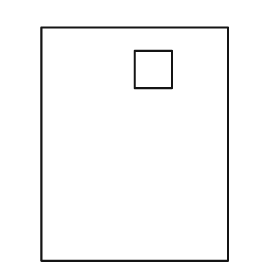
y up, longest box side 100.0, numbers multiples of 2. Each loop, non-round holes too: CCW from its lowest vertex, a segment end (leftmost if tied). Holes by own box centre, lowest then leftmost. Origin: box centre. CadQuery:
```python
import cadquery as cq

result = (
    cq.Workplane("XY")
    .moveTo(-40.0, -50.0)
    .lineTo(40.0, -50.0)
    .lineTo(40.0, 50.0)
    .lineTo(-40.0, 50.0)
    .close()
    .moveTo(0.0, 24.0)
    .lineTo(16.0, 24.0)
    .lineTo(16.0, 40.0)
    .lineTo(0.0, 40.0)
    .close()
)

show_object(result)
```